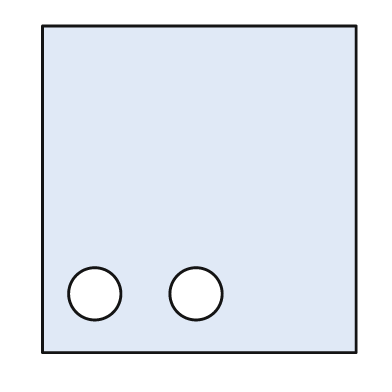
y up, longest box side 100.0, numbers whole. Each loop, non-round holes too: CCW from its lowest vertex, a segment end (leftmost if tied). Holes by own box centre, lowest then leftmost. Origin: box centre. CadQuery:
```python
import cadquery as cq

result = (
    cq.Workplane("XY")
    .moveTo(-48.0, -50.0)
    .lineTo(48.0, -50.0)
    .lineTo(48.0, 50.0)
    .lineTo(-48.0, 50.0)
    .close()
    .moveTo(-32.0, -32.0)
    .circle(8.0)
    .moveTo(-1.0, -32.0)
    .circle(8.0)
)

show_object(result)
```